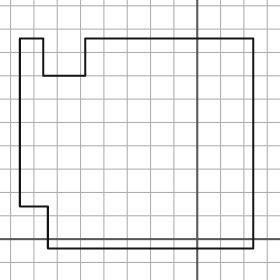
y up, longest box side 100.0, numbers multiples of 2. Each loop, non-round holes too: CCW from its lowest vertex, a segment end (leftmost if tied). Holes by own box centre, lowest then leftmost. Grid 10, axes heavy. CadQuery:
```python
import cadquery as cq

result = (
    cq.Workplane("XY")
    .moveTo(-64.0, -4.0)
    .lineTo(24.0, -4.0)
    .lineTo(24.0, 86.0)
    .lineTo(-48.0, 86.0)
    .lineTo(-48.0, 70.0)
    .lineTo(-66.0, 70.0)
    .lineTo(-66.0, 86.0)
    .lineTo(-76.0, 86.0)
    .lineTo(-76.0, 14.0)
    .lineTo(-64.0, 14.0)
    .close()
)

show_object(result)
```